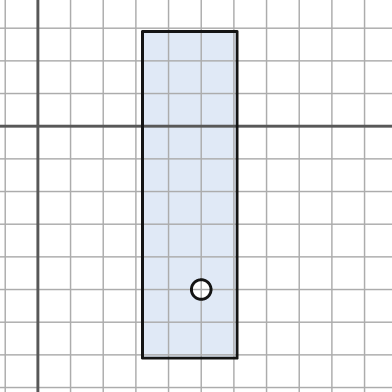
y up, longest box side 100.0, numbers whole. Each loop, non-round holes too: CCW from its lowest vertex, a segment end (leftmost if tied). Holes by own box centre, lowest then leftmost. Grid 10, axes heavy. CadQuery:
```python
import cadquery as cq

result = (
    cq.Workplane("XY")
    .moveTo(32.0, -71.0)
    .lineTo(61.0, -71.0)
    .lineTo(61.0, 29.0)
    .lineTo(32.0, 29.0)
    .close()
    .moveTo(50.0, -50.0)
    .circle(3.0)
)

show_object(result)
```